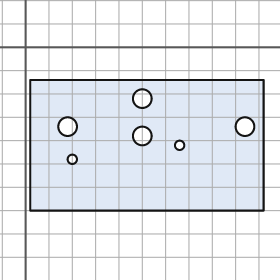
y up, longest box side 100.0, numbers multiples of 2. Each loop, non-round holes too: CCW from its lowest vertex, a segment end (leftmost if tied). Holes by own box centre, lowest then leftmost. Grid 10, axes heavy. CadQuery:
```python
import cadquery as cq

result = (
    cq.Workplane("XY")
    .moveTo(2.0, -70.0)
    .lineTo(102.0, -70.0)
    .lineTo(102.0, -14.0)
    .lineTo(2.0, -14.0)
    .close()
    .moveTo(20.0, -48.0)
    .circle(2.0)
    .moveTo(66.0, -42.0)
    .circle(2.0)
    .moveTo(50.0, -38.0)
    .circle(4.0)
    .moveTo(18.0, -34.0)
    .circle(4.0)
    .moveTo(94.0, -34.0)
    .circle(4.0)
    .moveTo(50.0, -22.0)
    .circle(4.0)
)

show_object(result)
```